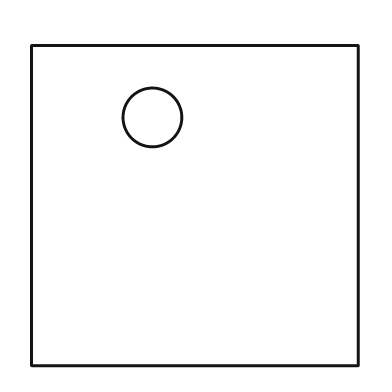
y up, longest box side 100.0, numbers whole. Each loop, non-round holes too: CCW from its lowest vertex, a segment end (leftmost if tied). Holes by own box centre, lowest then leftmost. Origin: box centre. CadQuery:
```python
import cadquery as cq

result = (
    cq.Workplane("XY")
    .moveTo(-50.0, -49.0)
    .lineTo(50.0, -49.0)
    .lineTo(50.0, 49.0)
    .lineTo(-50.0, 49.0)
    .close()
    .moveTo(-13.0, 27.0)
    .circle(9.0)
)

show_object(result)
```